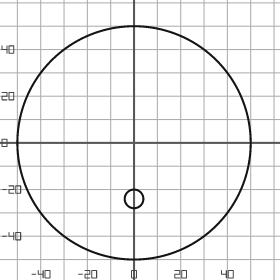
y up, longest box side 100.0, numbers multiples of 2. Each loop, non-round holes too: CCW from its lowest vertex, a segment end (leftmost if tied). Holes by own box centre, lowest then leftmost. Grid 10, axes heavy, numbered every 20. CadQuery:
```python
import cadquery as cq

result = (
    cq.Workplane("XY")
    .moveTo(0.0, 0.0)
    .circle(50.0)
    .moveTo(0.0, -24.0)
    .circle(4.0)
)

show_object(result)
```